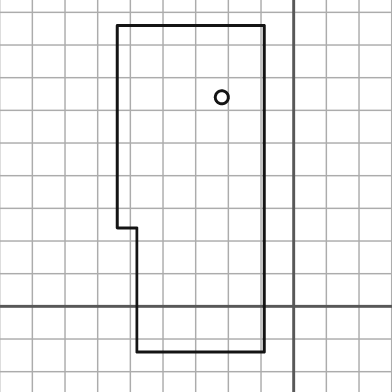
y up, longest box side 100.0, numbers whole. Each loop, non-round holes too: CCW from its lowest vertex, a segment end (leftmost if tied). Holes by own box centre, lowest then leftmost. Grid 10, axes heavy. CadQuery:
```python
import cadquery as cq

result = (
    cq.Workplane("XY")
    .moveTo(-48.0, -14.0)
    .lineTo(-9.0, -14.0)
    .lineTo(-9.0, 86.0)
    .lineTo(-54.0, 86.0)
    .lineTo(-54.0, 24.0)
    .lineTo(-48.0, 24.0)
    .close()
    .moveTo(-22.0, 64.0)
    .circle(2.0)
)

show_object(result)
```